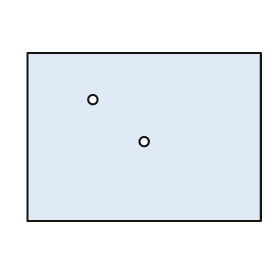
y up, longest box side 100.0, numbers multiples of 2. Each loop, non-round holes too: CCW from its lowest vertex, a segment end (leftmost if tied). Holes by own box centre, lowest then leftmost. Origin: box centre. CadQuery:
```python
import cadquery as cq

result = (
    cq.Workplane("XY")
    .moveTo(-50.0, -36.0)
    .lineTo(50.0, -36.0)
    .lineTo(50.0, 36.0)
    .lineTo(-50.0, 36.0)
    .close()
    .moveTo(0.0, -2.0)
    .circle(2.0)
    .moveTo(-22.0, 16.0)
    .circle(2.0)
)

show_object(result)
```